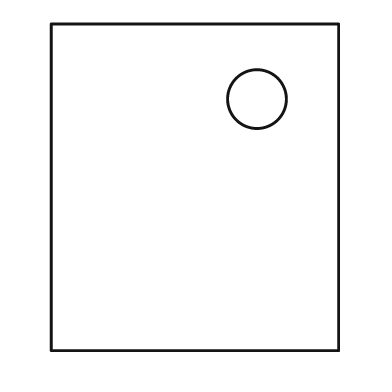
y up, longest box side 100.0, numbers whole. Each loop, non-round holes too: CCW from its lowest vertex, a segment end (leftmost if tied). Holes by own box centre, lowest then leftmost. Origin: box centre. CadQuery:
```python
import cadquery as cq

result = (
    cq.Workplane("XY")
    .moveTo(-44.0, -50.0)
    .lineTo(44.0, -50.0)
    .lineTo(44.0, 50.0)
    .lineTo(-44.0, 50.0)
    .close()
    .moveTo(19.0, 27.0)
    .circle(9.0)
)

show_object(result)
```